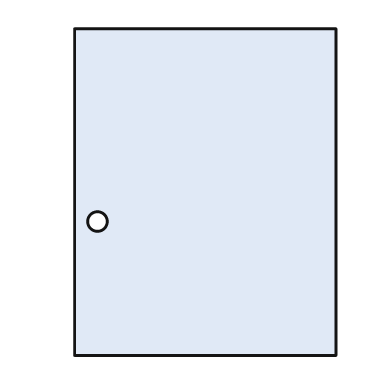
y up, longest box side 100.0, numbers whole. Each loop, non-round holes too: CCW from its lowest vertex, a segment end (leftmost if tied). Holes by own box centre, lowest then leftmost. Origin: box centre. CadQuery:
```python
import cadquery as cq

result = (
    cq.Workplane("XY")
    .moveTo(-40.0, -50.0)
    .lineTo(40.0, -50.0)
    .lineTo(40.0, 50.0)
    .lineTo(-40.0, 50.0)
    .close()
    .moveTo(-33.0, -9.0)
    .circle(3.0)
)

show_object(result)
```